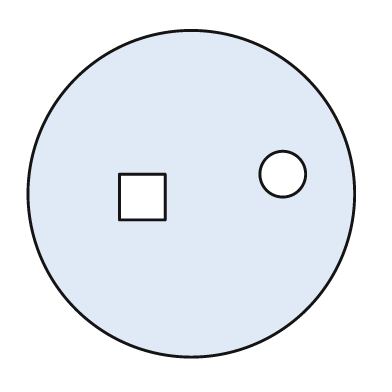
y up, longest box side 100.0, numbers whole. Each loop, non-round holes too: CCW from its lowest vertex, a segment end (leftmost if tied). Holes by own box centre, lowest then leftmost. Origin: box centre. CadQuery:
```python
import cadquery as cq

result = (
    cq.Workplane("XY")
    .moveTo(0.0, 0.0)
    .circle(50.0)
    .moveTo(-22.0, -8.0)
    .lineTo(-8.0, -8.0)
    .lineTo(-8.0, 6.0)
    .lineTo(-22.0, 6.0)
    .close()
    .moveTo(28.0, 6.0)
    .circle(7.0)
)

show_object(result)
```